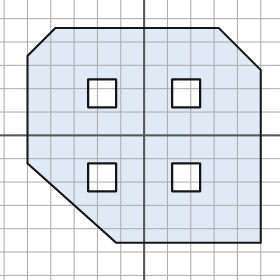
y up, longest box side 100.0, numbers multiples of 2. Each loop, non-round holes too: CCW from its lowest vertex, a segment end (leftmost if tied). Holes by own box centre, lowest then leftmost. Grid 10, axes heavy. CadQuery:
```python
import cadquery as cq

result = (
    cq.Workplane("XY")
    .moveTo(-12.0, -46.0)
    .lineTo(50.0, -46.0)
    .lineTo(50.0, 28.0)
    .lineTo(32.0, 46.0)
    .lineTo(-38.0, 46.0)
    .lineTo(-50.0, 34.0)
    .lineTo(-50.0, -12.0)
    .close()
    .moveTo(-24.0, -24.0)
    .lineTo(-12.0, -24.0)
    .lineTo(-12.0, -12.0)
    .lineTo(-24.0, -12.0)
    .close()
    .moveTo(12.0, -24.0)
    .lineTo(24.0, -24.0)
    .lineTo(24.0, -12.0)
    .lineTo(12.0, -12.0)
    .close()
    .moveTo(-24.0, 12.0)
    .lineTo(-12.0, 12.0)
    .lineTo(-12.0, 24.0)
    .lineTo(-24.0, 24.0)
    .close()
    .moveTo(12.0, 12.0)
    .lineTo(24.0, 12.0)
    .lineTo(24.0, 24.0)
    .lineTo(12.0, 24.0)
    .close()
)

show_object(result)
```